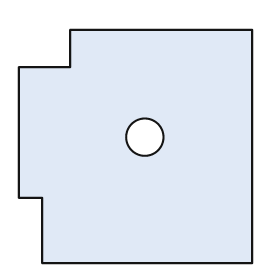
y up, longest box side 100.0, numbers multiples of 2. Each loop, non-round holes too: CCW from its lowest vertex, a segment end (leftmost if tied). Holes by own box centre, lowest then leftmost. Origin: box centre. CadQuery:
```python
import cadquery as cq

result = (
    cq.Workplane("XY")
    .moveTo(-40.0, -50.0)
    .lineTo(50.0, -50.0)
    .lineTo(50.0, 50.0)
    .lineTo(-28.0, 50.0)
    .lineTo(-28.0, 34.0)
    .lineTo(-50.0, 34.0)
    .lineTo(-50.0, -22.0)
    .lineTo(-40.0, -22.0)
    .close()
    .moveTo(4.0, 4.0)
    .circle(8.0)
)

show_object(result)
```